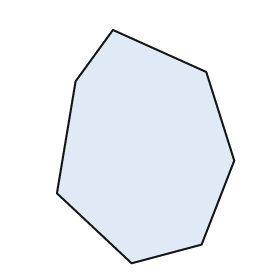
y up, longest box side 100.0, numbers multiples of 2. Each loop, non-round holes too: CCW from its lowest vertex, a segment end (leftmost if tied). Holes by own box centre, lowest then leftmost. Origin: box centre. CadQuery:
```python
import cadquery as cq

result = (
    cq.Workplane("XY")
    .moveTo(-6.0, -50.0)
    .lineTo(24.0, -42.0)
    .lineTo(38.0, -6.0)
    .lineTo(26.0, 32.0)
    .lineTo(-14.0, 50.0)
    .lineTo(-30.0, 28.0)
    .lineTo(-38.0, -20.0)
    .close()
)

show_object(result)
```